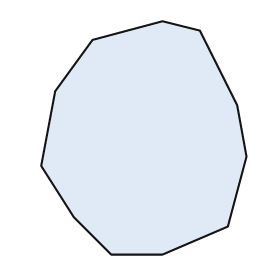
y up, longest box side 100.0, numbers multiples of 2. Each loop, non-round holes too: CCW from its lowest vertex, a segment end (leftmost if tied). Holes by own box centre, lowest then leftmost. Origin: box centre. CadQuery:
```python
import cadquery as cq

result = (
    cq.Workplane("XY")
    .moveTo(-14.0, -50.0)
    .lineTo(8.0, -50.0)
    .lineTo(36.0, -38.0)
    .lineTo(44.0, -8.0)
    .lineTo(40.0, 14.0)
    .lineTo(24.0, 46.0)
    .lineTo(8.0, 50.0)
    .lineTo(-22.0, 42.0)
    .lineTo(-38.0, 20.0)
    .lineTo(-44.0, -12.0)
    .lineTo(-30.0, -34.0)
    .close()
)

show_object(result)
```